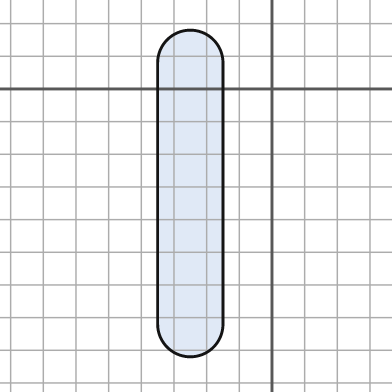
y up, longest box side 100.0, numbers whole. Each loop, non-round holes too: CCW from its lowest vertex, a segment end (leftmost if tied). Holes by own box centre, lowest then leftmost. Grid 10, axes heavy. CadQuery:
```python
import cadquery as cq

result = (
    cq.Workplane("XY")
    .moveTo(-35.0, -72.0)
    .threePointArc((-25.0, -82.0), (-15.0, -72.0))
    .lineTo(-15.0, 8.0)
    .threePointArc((-25.0, 18.0), (-35.0, 8.0))
    .close()
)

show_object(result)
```